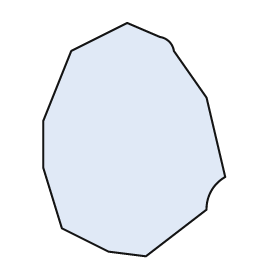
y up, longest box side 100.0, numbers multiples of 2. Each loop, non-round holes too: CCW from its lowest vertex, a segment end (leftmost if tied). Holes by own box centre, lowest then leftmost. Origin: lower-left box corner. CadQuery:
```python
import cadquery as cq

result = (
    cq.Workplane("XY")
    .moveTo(44.0, 0.0)
    .lineTo(70.0, 20.0)
    .threePointArc((72.0, 28.0), (78.0, 34.0))
    .lineTo(70.0, 68.0)
    .lineTo(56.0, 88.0)
    .threePointArc((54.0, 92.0), (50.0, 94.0))
    .lineTo(36.0, 100.0)
    .lineTo(12.0, 88.0)
    .lineTo(0.0, 58.0)
    .lineTo(0.0, 38.0)
    .lineTo(8.0, 12.0)
    .lineTo(28.0, 2.0)
    .close()
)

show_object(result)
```